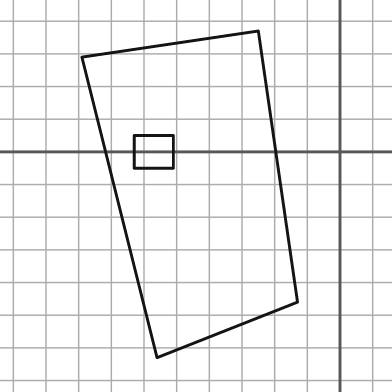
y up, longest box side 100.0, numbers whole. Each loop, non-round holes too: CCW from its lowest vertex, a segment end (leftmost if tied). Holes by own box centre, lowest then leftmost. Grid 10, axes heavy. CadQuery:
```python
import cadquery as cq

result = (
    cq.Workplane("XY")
    .moveTo(-56.0, -63.0)
    .lineTo(-13.0, -46.0)
    .lineTo(-25.0, 37.0)
    .lineTo(-79.0, 29.0)
    .close()
    .moveTo(-63.0, -5.0)
    .lineTo(-51.0, -5.0)
    .lineTo(-51.0, 5.0)
    .lineTo(-63.0, 5.0)
    .close()
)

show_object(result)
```